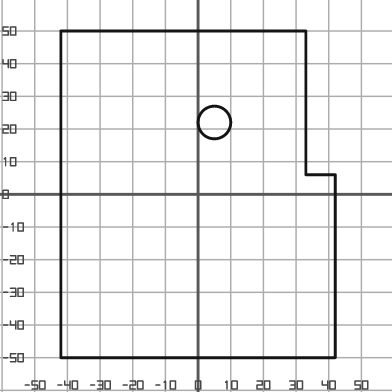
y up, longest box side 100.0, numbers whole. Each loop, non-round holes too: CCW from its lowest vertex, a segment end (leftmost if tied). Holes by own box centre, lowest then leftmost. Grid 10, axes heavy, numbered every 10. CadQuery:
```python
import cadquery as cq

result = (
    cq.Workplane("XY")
    .moveTo(-42.0, -50.0)
    .lineTo(42.0, -50.0)
    .lineTo(42.0, 6.0)
    .lineTo(33.0, 6.0)
    .lineTo(33.0, 50.0)
    .lineTo(-42.0, 50.0)
    .close()
    .moveTo(5.0, 22.0)
    .circle(5.0)
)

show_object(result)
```